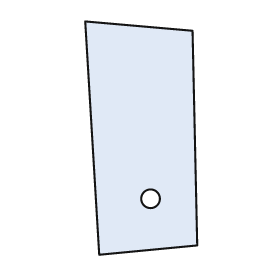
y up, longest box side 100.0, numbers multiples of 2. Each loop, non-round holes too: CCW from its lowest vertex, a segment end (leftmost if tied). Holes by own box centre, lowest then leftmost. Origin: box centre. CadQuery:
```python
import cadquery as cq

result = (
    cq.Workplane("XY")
    .moveTo(-18.0, -50.0)
    .lineTo(24.0, -46.0)
    .lineTo(22.0, 46.0)
    .lineTo(-24.0, 50.0)
    .close()
    .moveTo(4.0, -26.0)
    .circle(4.0)
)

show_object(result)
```